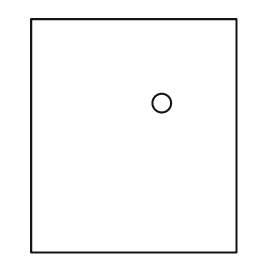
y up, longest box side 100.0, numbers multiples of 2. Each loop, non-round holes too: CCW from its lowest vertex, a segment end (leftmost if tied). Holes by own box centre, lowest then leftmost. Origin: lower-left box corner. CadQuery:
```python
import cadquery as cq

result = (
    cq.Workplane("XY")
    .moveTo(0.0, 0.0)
    .lineTo(88.0, 0.0)
    .lineTo(88.0, 100.0)
    .lineTo(0.0, 100.0)
    .close()
    .moveTo(56.0, 64.0)
    .circle(4.0)
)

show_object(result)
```